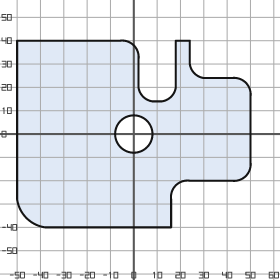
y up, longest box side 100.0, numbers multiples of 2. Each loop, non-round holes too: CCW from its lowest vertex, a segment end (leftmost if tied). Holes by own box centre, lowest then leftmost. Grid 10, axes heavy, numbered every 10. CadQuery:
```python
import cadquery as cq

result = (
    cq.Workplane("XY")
    .moveTo(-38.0, -40.0)
    .lineTo(16.0, -40.0)
    .lineTo(16.0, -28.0)
    .threePointArc((18.0, -22.0), (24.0, -20.0))
    .lineTo(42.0, -20.0)
    .threePointArc((48.0, -18.0), (50.0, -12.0))
    .lineTo(50.0, 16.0)
    .threePointArc((48.0, 22.0), (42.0, 24.0))
    .lineTo(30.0, 24.0)
    .threePointArc((26.0, 26.0), (24.0, 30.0))
    .lineTo(24.0, 40.0)
    .lineTo(18.0, 40.0)
    .lineTo(18.0, 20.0)
    .threePointArc((16.0, 16.0), (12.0, 14.0))
    .lineTo(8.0, 14.0)
    .threePointArc((4.0, 16.0), (2.0, 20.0))
    .lineTo(2.0, 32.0)
    .threePointArc((0.0, 38.0), (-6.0, 40.0))
    .lineTo(-50.0, 40.0)
    .lineTo(-50.0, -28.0)
    .threePointArc((-46.0, -36.0), (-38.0, -40.0))
    .close()
    .moveTo(0.0, 0.0)
    .circle(8.0)
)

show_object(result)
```